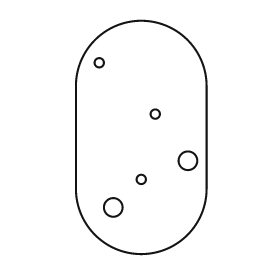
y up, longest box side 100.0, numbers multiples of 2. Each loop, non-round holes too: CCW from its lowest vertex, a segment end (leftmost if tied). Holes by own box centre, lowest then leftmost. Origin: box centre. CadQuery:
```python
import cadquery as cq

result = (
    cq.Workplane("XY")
    .moveTo(-28.0, -22.0)
    .threePointArc((0.0, -50.0), (28.0, -22.0))
    .lineTo(28.0, 22.0)
    .threePointArc((0.0, 50.0), (-28.0, 22.0))
    .close()
    .moveTo(-12.0, -30.0)
    .circle(4.0)
    .moveTo(0.0, -18.0)
    .circle(2.0)
    .moveTo(20.0, -10.0)
    .circle(4.0)
    .moveTo(6.0, 10.0)
    .circle(2.0)
    .moveTo(-18.0, 32.0)
    .circle(2.0)
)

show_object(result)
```